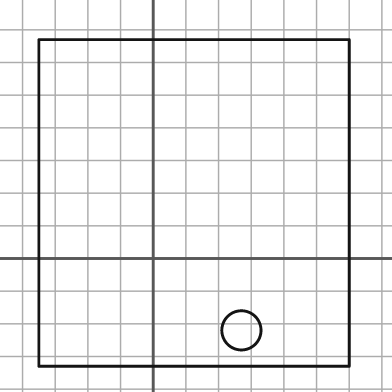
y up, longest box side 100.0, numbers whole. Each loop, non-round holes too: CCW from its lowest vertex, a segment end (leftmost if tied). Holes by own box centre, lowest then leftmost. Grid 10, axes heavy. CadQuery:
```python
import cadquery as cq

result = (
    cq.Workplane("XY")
    .moveTo(-35.0, -33.0)
    .lineTo(60.0, -33.0)
    .lineTo(60.0, 67.0)
    .lineTo(-35.0, 67.0)
    .close()
    .moveTo(27.0, -22.0)
    .circle(6.0)
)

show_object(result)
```